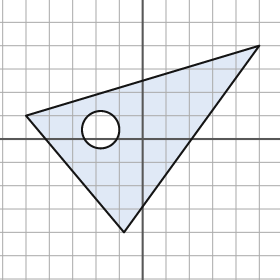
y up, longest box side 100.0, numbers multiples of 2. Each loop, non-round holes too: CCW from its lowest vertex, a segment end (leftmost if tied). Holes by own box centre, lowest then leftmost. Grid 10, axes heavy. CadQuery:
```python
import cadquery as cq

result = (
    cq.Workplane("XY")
    .moveTo(-8.0, -40.0)
    .lineTo(50.0, 40.0)
    .lineTo(-50.0, 10.0)
    .close()
    .moveTo(-18.0, 4.0)
    .circle(8.0)
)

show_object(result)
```